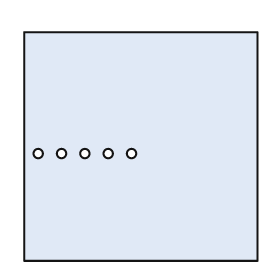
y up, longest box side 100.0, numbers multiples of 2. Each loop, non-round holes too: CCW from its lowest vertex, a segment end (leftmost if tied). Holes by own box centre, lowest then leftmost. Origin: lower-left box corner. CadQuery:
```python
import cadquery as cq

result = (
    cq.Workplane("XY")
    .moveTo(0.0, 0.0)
    .lineTo(100.0, 0.0)
    .lineTo(100.0, 98.0)
    .lineTo(0.0, 98.0)
    .close()
    .moveTo(6.0, 46.0)
    .circle(2.0)
    .moveTo(16.0, 46.0)
    .circle(2.0)
    .moveTo(26.0, 46.0)
    .circle(2.0)
    .moveTo(36.0, 46.0)
    .circle(2.0)
    .moveTo(46.0, 46.0)
    .circle(2.0)
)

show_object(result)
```